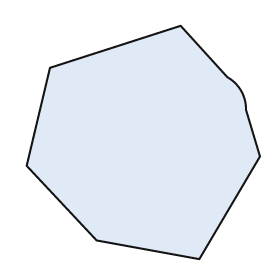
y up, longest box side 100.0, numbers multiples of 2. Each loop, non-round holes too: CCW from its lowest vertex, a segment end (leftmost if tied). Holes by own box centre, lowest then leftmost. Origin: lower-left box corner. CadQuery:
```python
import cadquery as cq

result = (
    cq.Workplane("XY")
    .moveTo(74.0, 0.0)
    .lineTo(100.0, 44.0)
    .lineTo(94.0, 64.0)
    .threePointArc((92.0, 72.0), (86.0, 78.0))
    .lineTo(66.0, 100.0)
    .lineTo(10.0, 82.0)
    .lineTo(0.0, 40.0)
    .lineTo(30.0, 8.0)
    .close()
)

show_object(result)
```